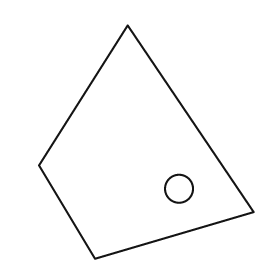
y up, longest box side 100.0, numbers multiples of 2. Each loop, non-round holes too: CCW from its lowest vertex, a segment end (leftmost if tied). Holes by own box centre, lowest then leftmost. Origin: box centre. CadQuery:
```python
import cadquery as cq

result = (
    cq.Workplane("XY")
    .moveTo(-22.0, -50.0)
    .lineTo(46.0, -30.0)
    .lineTo(-8.0, 50.0)
    .lineTo(-46.0, -10.0)
    .close()
    .moveTo(14.0, -20.0)
    .circle(6.0)
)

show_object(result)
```